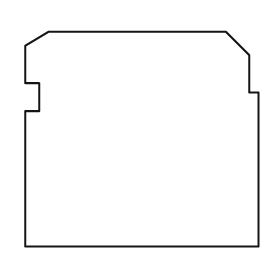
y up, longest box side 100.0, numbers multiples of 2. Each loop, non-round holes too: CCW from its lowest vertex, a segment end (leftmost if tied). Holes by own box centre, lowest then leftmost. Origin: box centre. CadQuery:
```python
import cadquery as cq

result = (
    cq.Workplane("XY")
    .moveTo(-50.0, -46.0)
    .lineTo(50.0, -46.0)
    .lineTo(50.0, 20.0)
    .lineTo(46.0, 20.0)
    .lineTo(46.0, 36.0)
    .lineTo(36.0, 46.0)
    .lineTo(-40.0, 46.0)
    .lineTo(-50.0, 40.0)
    .lineTo(-50.0, 24.0)
    .lineTo(-44.0, 24.0)
    .lineTo(-44.0, 12.0)
    .lineTo(-50.0, 12.0)
    .close()
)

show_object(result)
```